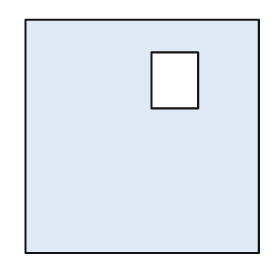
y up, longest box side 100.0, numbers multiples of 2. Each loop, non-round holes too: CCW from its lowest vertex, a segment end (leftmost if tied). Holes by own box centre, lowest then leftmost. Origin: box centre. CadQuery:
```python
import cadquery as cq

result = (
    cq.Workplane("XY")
    .moveTo(-50.0, -50.0)
    .lineTo(50.0, -50.0)
    .lineTo(50.0, 50.0)
    .lineTo(-50.0, 50.0)
    .close()
    .moveTo(4.0, 12.0)
    .lineTo(24.0, 12.0)
    .lineTo(24.0, 36.0)
    .lineTo(4.0, 36.0)
    .close()
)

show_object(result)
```